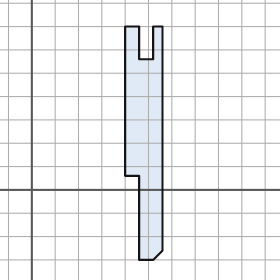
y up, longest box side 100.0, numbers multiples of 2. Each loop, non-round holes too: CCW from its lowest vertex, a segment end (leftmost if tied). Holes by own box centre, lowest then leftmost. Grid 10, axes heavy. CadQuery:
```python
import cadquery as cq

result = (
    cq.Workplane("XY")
    .moveTo(46.0, -30.0)
    .lineTo(52.0, -30.0)
    .lineTo(56.0, -26.0)
    .lineTo(56.0, 70.0)
    .lineTo(52.0, 70.0)
    .lineTo(52.0, 56.0)
    .lineTo(46.0, 56.0)
    .lineTo(46.0, 70.0)
    .lineTo(40.0, 70.0)
    .lineTo(40.0, 6.0)
    .lineTo(46.0, 6.0)
    .close()
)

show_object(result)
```